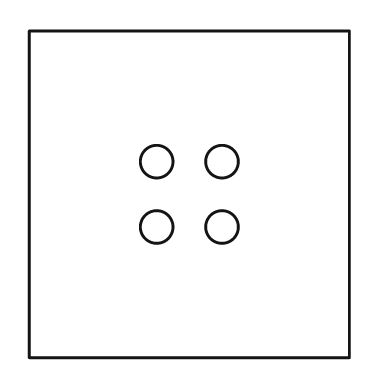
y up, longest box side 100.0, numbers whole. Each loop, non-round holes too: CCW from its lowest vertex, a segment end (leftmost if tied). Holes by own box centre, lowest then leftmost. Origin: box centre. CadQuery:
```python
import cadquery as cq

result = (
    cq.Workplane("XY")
    .moveTo(-49.0, -50.0)
    .lineTo(49.0, -50.0)
    .lineTo(49.0, 50.0)
    .lineTo(-49.0, 50.0)
    .close()
    .moveTo(-10.0, -10.0)
    .circle(5.0)
    .moveTo(10.0, -10.0)
    .circle(5.0)
    .moveTo(-10.0, 10.0)
    .circle(5.0)
    .moveTo(10.0, 10.0)
    .circle(5.0)
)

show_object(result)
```